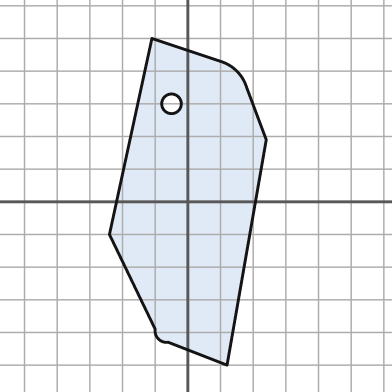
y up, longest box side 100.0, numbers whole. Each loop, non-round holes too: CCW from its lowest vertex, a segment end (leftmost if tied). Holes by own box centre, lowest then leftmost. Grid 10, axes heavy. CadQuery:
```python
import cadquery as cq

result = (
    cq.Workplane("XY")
    .moveTo(12.0, -50.0)
    .lineTo(24.0, 19.0)
    .lineTo(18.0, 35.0)
    .threePointArc((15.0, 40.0), (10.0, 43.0))
    .lineTo(-11.0, 50.0)
    .lineTo(-24.0, -10.0)
    .lineTo(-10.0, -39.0)
    .threePointArc((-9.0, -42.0), (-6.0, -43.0))
    .close()
    .moveTo(-5.0, 30.0)
    .circle(3.0)
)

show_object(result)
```